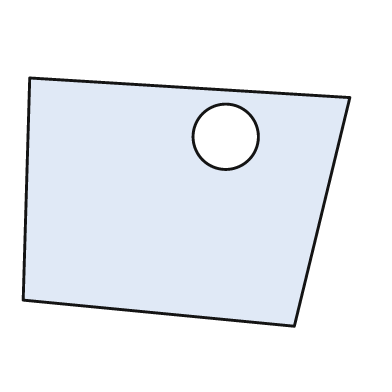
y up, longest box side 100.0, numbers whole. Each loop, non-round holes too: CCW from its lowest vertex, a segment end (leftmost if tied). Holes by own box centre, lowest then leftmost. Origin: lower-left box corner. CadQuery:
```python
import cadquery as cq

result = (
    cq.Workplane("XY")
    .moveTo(83.0, 0.0)
    .lineTo(100.0, 70.0)
    .lineTo(2.0, 76.0)
    .lineTo(0.0, 8.0)
    .close()
    .moveTo(62.0, 58.0)
    .circle(10.0)
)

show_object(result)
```